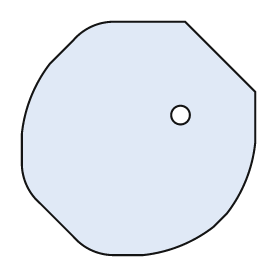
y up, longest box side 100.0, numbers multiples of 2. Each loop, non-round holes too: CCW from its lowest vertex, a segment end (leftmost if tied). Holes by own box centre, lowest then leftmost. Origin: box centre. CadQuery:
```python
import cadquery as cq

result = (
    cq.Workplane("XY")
    .moveTo(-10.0, -50.0)
    .lineTo(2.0, -50.0)
    .threePointArc((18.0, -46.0), (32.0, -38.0))
    .lineTo(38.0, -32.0)
    .threePointArc((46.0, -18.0), (50.0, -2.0))
    .lineTo(50.0, 20.0)
    .lineTo(20.0, 50.0)
    .lineTo(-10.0, 50.0)
    .threePointArc((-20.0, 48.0), (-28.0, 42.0))
    .lineTo(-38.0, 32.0)
    .threePointArc((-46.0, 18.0), (-50.0, 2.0))
    .lineTo(-50.0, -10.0)
    .threePointArc((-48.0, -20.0), (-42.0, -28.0))
    .lineTo(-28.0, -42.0)
    .threePointArc((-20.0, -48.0), (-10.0, -50.0))
    .close()
    .moveTo(18.0, 10.0)
    .circle(4.0)
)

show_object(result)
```